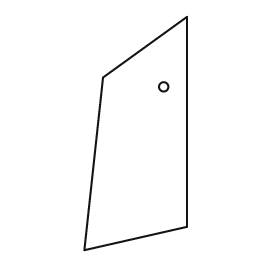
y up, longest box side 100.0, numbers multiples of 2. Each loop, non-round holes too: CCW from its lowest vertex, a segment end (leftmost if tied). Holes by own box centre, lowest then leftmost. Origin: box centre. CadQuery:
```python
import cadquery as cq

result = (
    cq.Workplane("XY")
    .moveTo(-22.0, -50.0)
    .lineTo(22.0, -40.0)
    .lineTo(22.0, 50.0)
    .lineTo(-14.0, 24.0)
    .close()
    .moveTo(12.0, 20.0)
    .circle(2.0)
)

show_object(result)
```